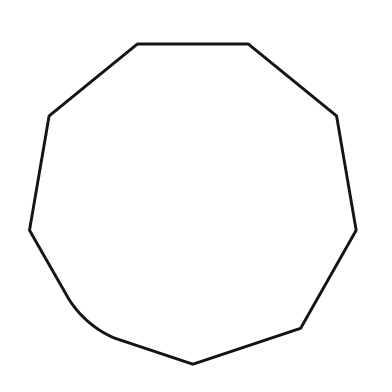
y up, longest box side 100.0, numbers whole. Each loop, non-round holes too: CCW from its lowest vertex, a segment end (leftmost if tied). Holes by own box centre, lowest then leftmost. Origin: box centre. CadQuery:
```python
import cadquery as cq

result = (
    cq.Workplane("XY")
    .moveTo(0.0, -49.0)
    .lineTo(33.0, -38.0)
    .lineTo(50.0, -8.0)
    .lineTo(44.0, 27.0)
    .lineTo(17.0, 49.0)
    .lineTo(-17.0, 49.0)
    .lineTo(-44.0, 27.0)
    .lineTo(-50.0, -8.0)
    .lineTo(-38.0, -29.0)
    .threePointArc((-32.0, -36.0), (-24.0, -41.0))
    .close()
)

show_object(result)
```